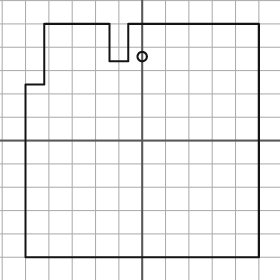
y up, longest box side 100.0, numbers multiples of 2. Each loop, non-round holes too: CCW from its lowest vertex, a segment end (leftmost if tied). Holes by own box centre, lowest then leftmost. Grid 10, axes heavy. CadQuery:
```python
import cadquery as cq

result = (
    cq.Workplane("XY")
    .moveTo(-50.0, -50.0)
    .lineTo(50.0, -50.0)
    .lineTo(50.0, 50.0)
    .lineTo(-6.0, 50.0)
    .lineTo(-6.0, 34.0)
    .lineTo(-14.0, 34.0)
    .lineTo(-14.0, 50.0)
    .lineTo(-42.0, 50.0)
    .lineTo(-42.0, 24.0)
    .lineTo(-50.0, 24.0)
    .close()
    .moveTo(0.0, 36.0)
    .circle(2.0)
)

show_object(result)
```